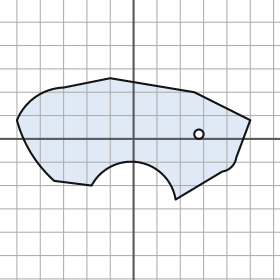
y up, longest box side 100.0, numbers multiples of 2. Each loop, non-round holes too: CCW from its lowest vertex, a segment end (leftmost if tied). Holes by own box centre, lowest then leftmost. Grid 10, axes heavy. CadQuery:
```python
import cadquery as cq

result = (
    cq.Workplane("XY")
    .moveTo(18.0, -26.0)
    .lineTo(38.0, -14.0)
    .threePointArc((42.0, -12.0), (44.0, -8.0))
    .lineTo(50.0, 8.0)
    .lineTo(26.0, 20.0)
    .lineTo(-10.0, 26.0)
    .lineTo(-30.0, 22.0)
    .threePointArc((-42.0, 18.0), (-50.0, 8.0))
    .threePointArc((-44.0, -6.0), (-34.0, -18.0))
    .lineTo(-18.0, -20.0)
    .threePointArc((2.0, -10.0), (18.0, -26.0))
    .close()
    .moveTo(28.0, 2.0)
    .circle(2.0)
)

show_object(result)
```